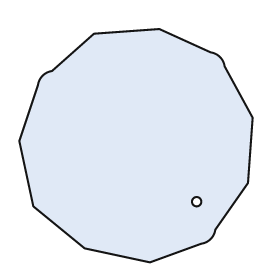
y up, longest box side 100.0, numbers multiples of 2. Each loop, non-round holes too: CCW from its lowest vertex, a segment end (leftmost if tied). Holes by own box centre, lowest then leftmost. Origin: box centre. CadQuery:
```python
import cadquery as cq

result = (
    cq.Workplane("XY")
    .moveTo(6.0, -50.0)
    .lineTo(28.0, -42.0)
    .threePointArc((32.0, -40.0), (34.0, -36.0))
    .lineTo(48.0, -16.0)
    .lineTo(50.0, 12.0)
    .lineTo(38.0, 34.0)
    .threePointArc((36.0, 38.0), (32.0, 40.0))
    .lineTo(10.0, 50.0)
    .lineTo(-18.0, 48.0)
    .lineTo(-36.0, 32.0)
    .threePointArc((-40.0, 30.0), (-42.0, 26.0))
    .lineTo(-50.0, 2.0)
    .lineTo(-44.0, -26.0)
    .lineTo(-22.0, -44.0)
    .close()
    .moveTo(26.0, -24.0)
    .circle(2.0)
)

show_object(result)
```